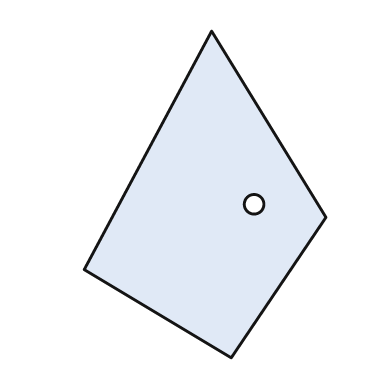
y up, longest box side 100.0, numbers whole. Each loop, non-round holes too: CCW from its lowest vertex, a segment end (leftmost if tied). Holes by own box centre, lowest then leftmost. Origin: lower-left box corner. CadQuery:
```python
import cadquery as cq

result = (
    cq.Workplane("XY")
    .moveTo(45.0, 0.0)
    .lineTo(74.0, 43.0)
    .lineTo(39.0, 100.0)
    .lineTo(0.0, 27.0)
    .close()
    .moveTo(52.0, 47.0)
    .circle(3.0)
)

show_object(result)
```